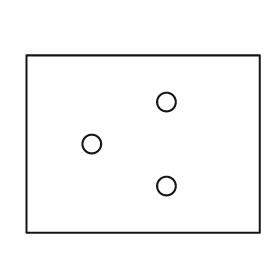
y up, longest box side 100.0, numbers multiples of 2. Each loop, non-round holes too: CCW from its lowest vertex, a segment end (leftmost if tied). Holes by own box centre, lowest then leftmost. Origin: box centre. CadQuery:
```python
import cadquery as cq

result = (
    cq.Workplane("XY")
    .moveTo(-50.0, -38.0)
    .lineTo(50.0, -38.0)
    .lineTo(50.0, 38.0)
    .lineTo(-50.0, 38.0)
    .close()
    .moveTo(10.0, -18.0)
    .circle(4.0)
    .moveTo(-22.0, 0.0)
    .circle(4.0)
    .moveTo(10.0, 18.0)
    .circle(4.0)
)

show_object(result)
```